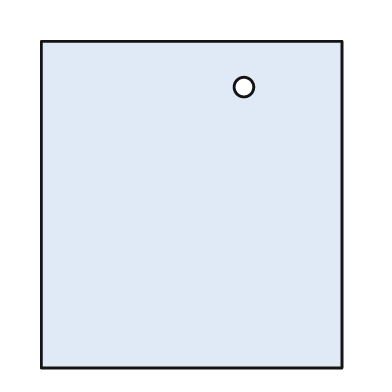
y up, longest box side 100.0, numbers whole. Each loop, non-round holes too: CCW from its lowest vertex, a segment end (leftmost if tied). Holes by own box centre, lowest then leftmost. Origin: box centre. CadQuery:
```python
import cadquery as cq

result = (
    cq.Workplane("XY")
    .moveTo(-46.0, -50.0)
    .lineTo(46.0, -50.0)
    .lineTo(46.0, 50.0)
    .lineTo(-46.0, 50.0)
    .close()
    .moveTo(16.0, 36.0)
    .circle(3.0)
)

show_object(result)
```